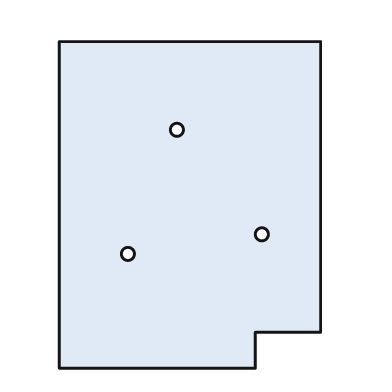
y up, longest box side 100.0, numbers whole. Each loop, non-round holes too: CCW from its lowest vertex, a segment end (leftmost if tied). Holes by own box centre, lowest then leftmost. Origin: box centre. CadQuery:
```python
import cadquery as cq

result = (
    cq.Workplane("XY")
    .moveTo(-40.0, -50.0)
    .lineTo(20.0, -50.0)
    .lineTo(20.0, -39.0)
    .lineTo(40.0, -39.0)
    .lineTo(40.0, 50.0)
    .lineTo(-40.0, 50.0)
    .close()
    .moveTo(-19.0, -15.0)
    .circle(2.0)
    .moveTo(22.0, -9.0)
    .circle(2.0)
    .moveTo(-4.0, 23.0)
    .circle(2.0)
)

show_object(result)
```